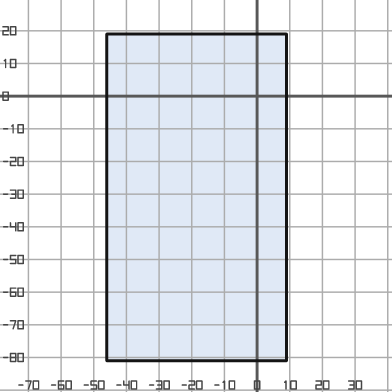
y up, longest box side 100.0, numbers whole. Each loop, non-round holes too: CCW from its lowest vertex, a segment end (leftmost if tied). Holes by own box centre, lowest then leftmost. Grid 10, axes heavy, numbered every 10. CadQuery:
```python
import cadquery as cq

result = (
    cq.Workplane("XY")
    .moveTo(-46.0, -81.0)
    .lineTo(9.0, -81.0)
    .lineTo(9.0, 19.0)
    .lineTo(-46.0, 19.0)
    .close()
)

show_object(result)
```